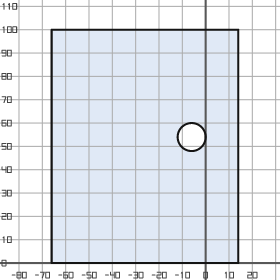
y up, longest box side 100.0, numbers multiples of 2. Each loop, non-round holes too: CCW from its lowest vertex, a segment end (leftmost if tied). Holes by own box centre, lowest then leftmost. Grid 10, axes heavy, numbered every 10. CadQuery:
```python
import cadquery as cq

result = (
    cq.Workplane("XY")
    .moveTo(-66.0, 0.0)
    .lineTo(14.0, 0.0)
    .lineTo(14.0, 100.0)
    .lineTo(-66.0, 100.0)
    .close()
    .moveTo(-6.0, 54.0)
    .circle(6.0)
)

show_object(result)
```